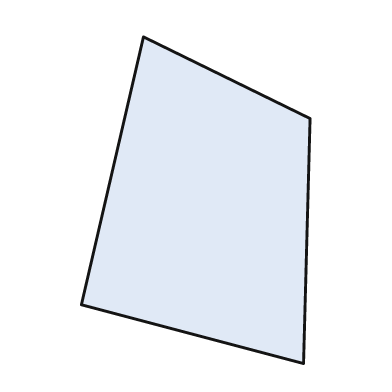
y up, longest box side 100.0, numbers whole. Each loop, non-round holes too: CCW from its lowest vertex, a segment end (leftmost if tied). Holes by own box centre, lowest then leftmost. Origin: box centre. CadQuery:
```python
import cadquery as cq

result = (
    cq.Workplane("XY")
    .moveTo(33.0, -50.0)
    .lineTo(35.0, 25.0)
    .lineTo(-16.0, 50.0)
    .lineTo(-35.0, -32.0)
    .close()
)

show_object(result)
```